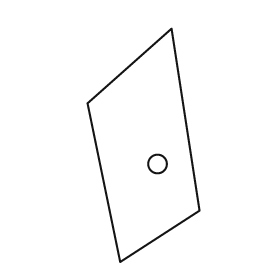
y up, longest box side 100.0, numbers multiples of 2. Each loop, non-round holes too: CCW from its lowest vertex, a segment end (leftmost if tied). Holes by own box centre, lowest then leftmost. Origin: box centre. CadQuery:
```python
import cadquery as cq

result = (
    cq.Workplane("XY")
    .moveTo(-10.0, -50.0)
    .lineTo(24.0, -28.0)
    .lineTo(12.0, 50.0)
    .lineTo(-24.0, 18.0)
    .close()
    .moveTo(6.0, -8.0)
    .circle(4.0)
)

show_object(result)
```